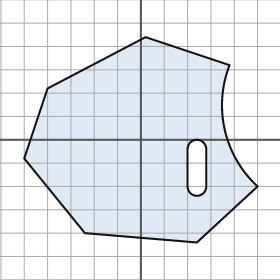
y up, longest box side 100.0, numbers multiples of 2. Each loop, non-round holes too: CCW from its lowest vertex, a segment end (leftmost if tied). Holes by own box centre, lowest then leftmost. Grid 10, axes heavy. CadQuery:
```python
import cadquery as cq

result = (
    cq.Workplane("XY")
    .moveTo(24.0, -44.0)
    .lineTo(50.0, -20.0)
    .threePointArc((36.0, 4.0), (38.0, 32.0))
    .lineTo(2.0, 44.0)
    .lineTo(-40.0, 22.0)
    .lineTo(-50.0, -8.0)
    .lineTo(-24.0, -40.0)
    .close()
    .moveTo(20.0, -20.0)
    .threePointArc((24.0, -24.0), (28.0, -20.0))
    .lineTo(28.0, -4.0)
    .threePointArc((24.0, 0.0), (20.0, -4.0))
    .close()
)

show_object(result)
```